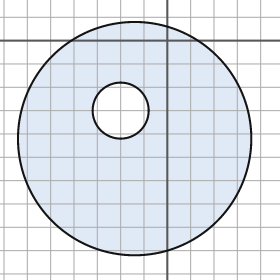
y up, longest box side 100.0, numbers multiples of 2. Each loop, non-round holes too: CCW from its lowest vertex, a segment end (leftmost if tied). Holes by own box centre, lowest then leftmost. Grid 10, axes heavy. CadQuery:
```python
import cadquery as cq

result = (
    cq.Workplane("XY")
    .moveTo(-14.0, -42.0)
    .circle(50.0)
    .moveTo(-20.0, -30.0)
    .circle(12.0)
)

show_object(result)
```